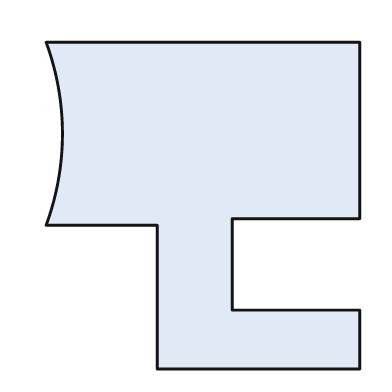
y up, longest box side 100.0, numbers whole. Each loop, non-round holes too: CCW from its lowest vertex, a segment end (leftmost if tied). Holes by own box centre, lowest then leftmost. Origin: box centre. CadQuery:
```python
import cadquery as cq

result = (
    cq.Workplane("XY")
    .moveTo(-14.0, -50.0)
    .lineTo(48.0, -50.0)
    .lineTo(48.0, -32.0)
    .lineTo(9.0, -32.0)
    .lineTo(9.0, -4.0)
    .lineTo(48.0, -4.0)
    .lineTo(48.0, 50.0)
    .lineTo(-48.0, 50.0)
    .threePointArc((-43.0, 22.0), (-48.0, -6.0))
    .lineTo(-14.0, -6.0)
    .close()
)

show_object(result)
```